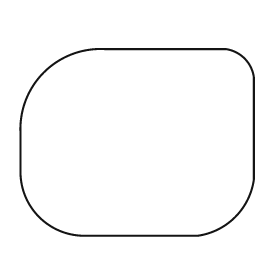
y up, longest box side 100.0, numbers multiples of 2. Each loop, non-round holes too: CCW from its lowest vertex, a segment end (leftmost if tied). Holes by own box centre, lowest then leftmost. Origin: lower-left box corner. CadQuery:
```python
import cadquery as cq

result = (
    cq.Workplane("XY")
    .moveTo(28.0, 0.0)
    .lineTo(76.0, 0.0)
    .threePointArc((92.0, 8.0), (100.0, 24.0))
    .lineTo(100.0, 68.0)
    .threePointArc((96.0, 76.0), (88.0, 80.0))
    .lineTo(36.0, 80.0)
    .threePointArc((10.0, 70.0), (0.0, 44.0))
    .lineTo(0.0, 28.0)
    .threePointArc((8.0, 8.0), (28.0, 0.0))
    .close()
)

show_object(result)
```